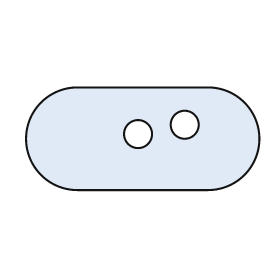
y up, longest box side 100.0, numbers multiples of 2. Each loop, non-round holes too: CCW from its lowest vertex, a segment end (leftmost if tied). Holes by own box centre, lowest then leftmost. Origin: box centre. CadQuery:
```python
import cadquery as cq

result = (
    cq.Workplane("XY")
    .moveTo(-28.0, -22.0)
    .lineTo(28.0, -22.0)
    .threePointArc((50.0, 0.0), (28.0, 22.0))
    .lineTo(-28.0, 22.0)
    .threePointArc((-50.0, 0.0), (-28.0, -22.0))
    .close()
    .moveTo(-2.0, 2.0)
    .circle(6.0)
    .moveTo(18.0, 6.0)
    .circle(6.0)
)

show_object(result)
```